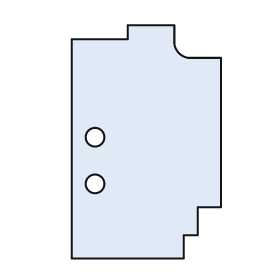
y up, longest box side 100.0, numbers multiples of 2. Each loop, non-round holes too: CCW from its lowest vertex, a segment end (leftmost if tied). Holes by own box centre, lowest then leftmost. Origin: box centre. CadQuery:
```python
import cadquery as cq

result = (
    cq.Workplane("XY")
    .moveTo(-32.0, -50.0)
    .lineTo(16.0, -50.0)
    .lineTo(16.0, -40.0)
    .lineTo(22.0, -40.0)
    .lineTo(22.0, -28.0)
    .lineTo(32.0, -28.0)
    .lineTo(32.0, 36.0)
    .lineTo(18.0, 36.0)
    .threePointArc((14.0, 38.0), (12.0, 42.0))
    .lineTo(12.0, 50.0)
    .lineTo(-8.0, 50.0)
    .lineTo(-8.0, 44.0)
    .lineTo(-32.0, 44.0)
    .close()
    .moveTo(-22.0, -18.0)
    .circle(4.0)
    .moveTo(-22.0, 2.0)
    .circle(4.0)
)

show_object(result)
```